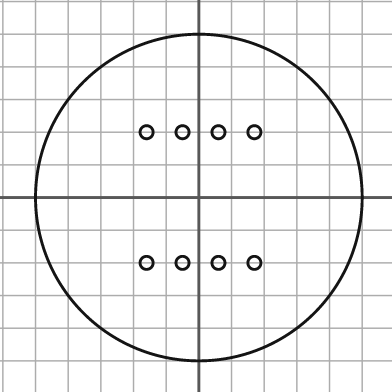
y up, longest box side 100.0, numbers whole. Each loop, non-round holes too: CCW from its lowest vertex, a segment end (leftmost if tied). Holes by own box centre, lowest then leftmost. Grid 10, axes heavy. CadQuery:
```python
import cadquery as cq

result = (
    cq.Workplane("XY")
    .moveTo(0.0, 0.0)
    .circle(50.0)
    .moveTo(-16.0, -20.0)
    .circle(2.0)
    .moveTo(-5.0, -20.0)
    .circle(2.0)
    .moveTo(6.0, -20.0)
    .circle(2.0)
    .moveTo(17.0, -20.0)
    .circle(2.0)
    .moveTo(-16.0, 20.0)
    .circle(2.0)
    .moveTo(-5.0, 20.0)
    .circle(2.0)
    .moveTo(6.0, 20.0)
    .circle(2.0)
    .moveTo(17.0, 20.0)
    .circle(2.0)
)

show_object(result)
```